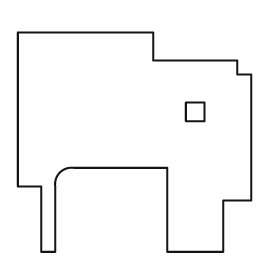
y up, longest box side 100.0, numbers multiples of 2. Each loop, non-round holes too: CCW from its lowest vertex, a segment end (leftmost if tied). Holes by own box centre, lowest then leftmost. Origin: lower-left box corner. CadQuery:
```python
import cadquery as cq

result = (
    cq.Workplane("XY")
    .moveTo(10.0, 0.0)
    .lineTo(16.0, 0.0)
    .lineTo(16.0, 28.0)
    .threePointArc((18.0, 34.0), (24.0, 36.0))
    .lineTo(64.0, 36.0)
    .lineTo(64.0, 0.0)
    .lineTo(88.0, 0.0)
    .lineTo(88.0, 22.0)
    .lineTo(100.0, 22.0)
    .lineTo(100.0, 76.0)
    .lineTo(94.0, 76.0)
    .lineTo(94.0, 82.0)
    .lineTo(58.0, 82.0)
    .lineTo(58.0, 94.0)
    .lineTo(0.0, 94.0)
    .lineTo(0.0, 28.0)
    .lineTo(10.0, 28.0)
    .close()
    .moveTo(72.0, 56.0)
    .lineTo(80.0, 56.0)
    .lineTo(80.0, 64.0)
    .lineTo(72.0, 64.0)
    .close()
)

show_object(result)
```